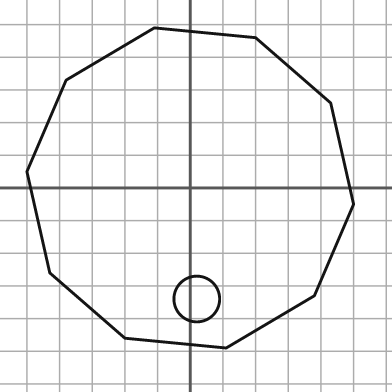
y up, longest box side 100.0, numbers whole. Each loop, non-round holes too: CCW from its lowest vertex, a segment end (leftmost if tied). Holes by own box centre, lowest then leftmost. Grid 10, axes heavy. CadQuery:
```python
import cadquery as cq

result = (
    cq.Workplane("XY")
    .moveTo(11.0, -49.0)
    .lineTo(38.0, -33.0)
    .lineTo(50.0, -5.0)
    .lineTo(43.0, 26.0)
    .lineTo(20.0, 46.0)
    .lineTo(-11.0, 49.0)
    .lineTo(-38.0, 33.0)
    .lineTo(-50.0, 5.0)
    .lineTo(-43.0, -26.0)
    .lineTo(-20.0, -46.0)
    .close()
    .moveTo(2.0, -34.0)
    .circle(7.0)
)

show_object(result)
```